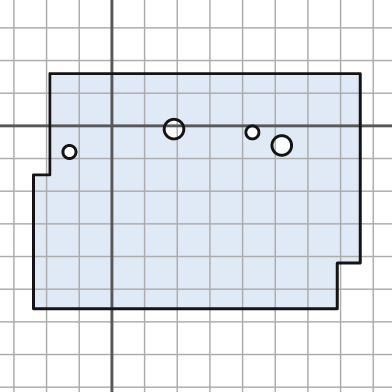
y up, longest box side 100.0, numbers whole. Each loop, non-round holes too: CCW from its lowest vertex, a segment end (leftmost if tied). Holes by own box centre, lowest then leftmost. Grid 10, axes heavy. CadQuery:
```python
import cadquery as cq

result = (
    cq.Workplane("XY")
    .moveTo(-24.0, -56.0)
    .lineTo(69.0, -56.0)
    .lineTo(69.0, -42.0)
    .lineTo(76.0, -42.0)
    .lineTo(76.0, 16.0)
    .lineTo(-19.0, 16.0)
    .lineTo(-19.0, -15.0)
    .lineTo(-24.0, -15.0)
    .close()
    .moveTo(-13.0, -8.0)
    .circle(2.0)
    .moveTo(52.0, -6.0)
    .circle(3.0)
    .moveTo(43.0, -2.0)
    .circle(2.0)
    .moveTo(19.0, -1.0)
    .circle(3.0)
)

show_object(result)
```